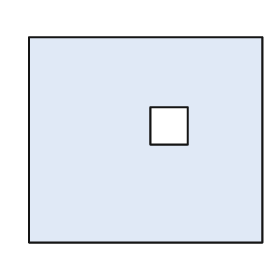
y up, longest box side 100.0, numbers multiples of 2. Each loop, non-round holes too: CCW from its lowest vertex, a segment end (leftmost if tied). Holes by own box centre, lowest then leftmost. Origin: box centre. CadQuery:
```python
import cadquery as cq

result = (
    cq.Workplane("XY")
    .moveTo(-50.0, -44.0)
    .lineTo(50.0, -44.0)
    .lineTo(50.0, 44.0)
    .lineTo(-50.0, 44.0)
    .close()
    .moveTo(2.0, -2.0)
    .lineTo(18.0, -2.0)
    .lineTo(18.0, 14.0)
    .lineTo(2.0, 14.0)
    .close()
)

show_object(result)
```